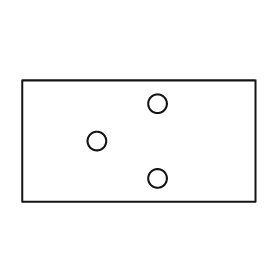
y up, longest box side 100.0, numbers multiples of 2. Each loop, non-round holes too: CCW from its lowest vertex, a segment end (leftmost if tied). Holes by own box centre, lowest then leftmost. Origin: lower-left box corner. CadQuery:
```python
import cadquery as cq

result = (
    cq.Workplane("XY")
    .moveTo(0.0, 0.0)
    .lineTo(100.0, 0.0)
    .lineTo(100.0, 52.0)
    .lineTo(0.0, 52.0)
    .close()
    .moveTo(58.0, 10.0)
    .circle(4.0)
    .moveTo(32.0, 26.0)
    .circle(4.0)
    .moveTo(58.0, 42.0)
    .circle(4.0)
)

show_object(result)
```